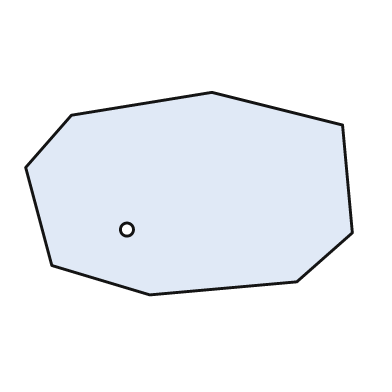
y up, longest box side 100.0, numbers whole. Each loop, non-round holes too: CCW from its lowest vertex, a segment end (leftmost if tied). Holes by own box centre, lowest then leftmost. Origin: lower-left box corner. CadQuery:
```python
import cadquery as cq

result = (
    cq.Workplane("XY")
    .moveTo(38.0, 0.0)
    .lineTo(83.0, 4.0)
    .lineTo(100.0, 19.0)
    .lineTo(97.0, 52.0)
    .lineTo(57.0, 62.0)
    .lineTo(14.0, 55.0)
    .lineTo(0.0, 39.0)
    .lineTo(8.0, 9.0)
    .close()
    .moveTo(31.0, 20.0)
    .circle(2.0)
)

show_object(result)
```